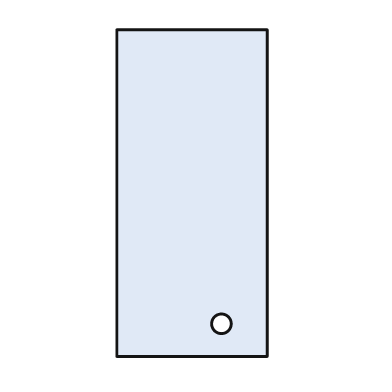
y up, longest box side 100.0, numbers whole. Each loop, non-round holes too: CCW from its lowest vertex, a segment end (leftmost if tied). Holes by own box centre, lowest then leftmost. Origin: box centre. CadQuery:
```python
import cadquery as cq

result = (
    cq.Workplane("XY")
    .moveTo(-23.0, -50.0)
    .lineTo(23.0, -50.0)
    .lineTo(23.0, 50.0)
    .lineTo(-23.0, 50.0)
    .close()
    .moveTo(9.0, -40.0)
    .circle(3.0)
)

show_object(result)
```